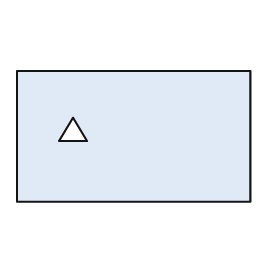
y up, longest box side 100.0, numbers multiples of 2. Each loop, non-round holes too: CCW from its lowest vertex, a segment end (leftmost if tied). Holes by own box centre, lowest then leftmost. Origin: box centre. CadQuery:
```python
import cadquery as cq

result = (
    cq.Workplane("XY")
    .moveTo(-50.0, -28.0)
    .lineTo(50.0, -28.0)
    .lineTo(50.0, 28.0)
    .lineTo(-50.0, 28.0)
    .close()
    .moveTo(-32.0, -2.0)
    .lineTo(-20.0, -2.0)
    .lineTo(-26.0, 8.0)
    .close()
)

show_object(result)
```